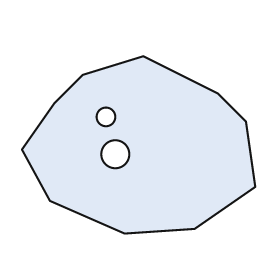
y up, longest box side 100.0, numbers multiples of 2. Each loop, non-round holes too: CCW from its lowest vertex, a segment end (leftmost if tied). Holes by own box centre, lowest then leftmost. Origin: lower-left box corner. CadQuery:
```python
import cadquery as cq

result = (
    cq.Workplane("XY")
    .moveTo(44.0, 0.0)
    .lineTo(74.0, 2.0)
    .lineTo(100.0, 20.0)
    .lineTo(96.0, 48.0)
    .lineTo(84.0, 60.0)
    .lineTo(52.0, 76.0)
    .lineTo(26.0, 68.0)
    .lineTo(14.0, 56.0)
    .lineTo(0.0, 36.0)
    .lineTo(12.0, 14.0)
    .close()
    .moveTo(40.0, 34.0)
    .circle(6.0)
    .moveTo(36.0, 50.0)
    .circle(4.0)
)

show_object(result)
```